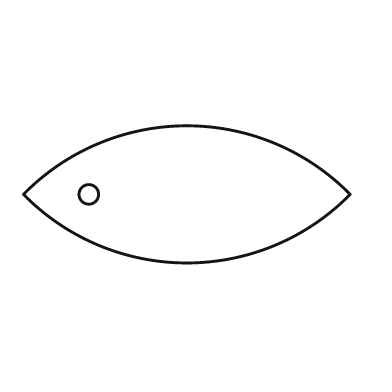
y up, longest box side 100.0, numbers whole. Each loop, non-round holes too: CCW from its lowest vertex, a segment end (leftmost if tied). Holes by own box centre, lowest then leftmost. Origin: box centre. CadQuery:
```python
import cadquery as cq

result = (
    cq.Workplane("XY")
    .moveTo(-50.0, 0.0)
    .threePointArc((0.0, -21.0), (50.0, 0.0))
    .threePointArc((0.0, 21.0), (-50.0, 0.0))
    .close()
    .moveTo(-30.0, 0.0)
    .circle(3.0)
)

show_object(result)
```